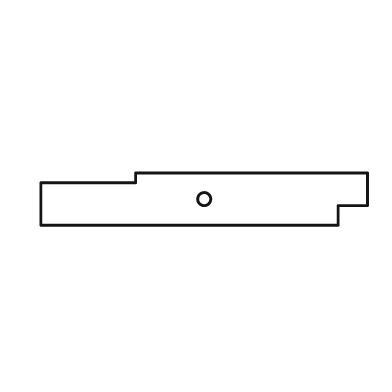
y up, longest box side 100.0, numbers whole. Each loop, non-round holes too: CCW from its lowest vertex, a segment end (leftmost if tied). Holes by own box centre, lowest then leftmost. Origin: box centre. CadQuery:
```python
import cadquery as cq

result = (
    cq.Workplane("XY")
    .moveTo(-50.0, -8.0)
    .lineTo(41.0, -8.0)
    .lineTo(41.0, -2.0)
    .lineTo(50.0, -2.0)
    .lineTo(50.0, 8.0)
    .lineTo(-21.0, 8.0)
    .lineTo(-21.0, 5.0)
    .lineTo(-50.0, 5.0)
    .close()
    .moveTo(0.0, 0.0)
    .circle(2.0)
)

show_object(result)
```